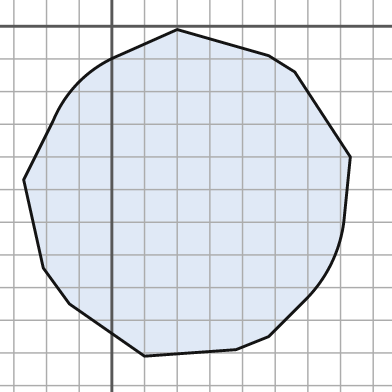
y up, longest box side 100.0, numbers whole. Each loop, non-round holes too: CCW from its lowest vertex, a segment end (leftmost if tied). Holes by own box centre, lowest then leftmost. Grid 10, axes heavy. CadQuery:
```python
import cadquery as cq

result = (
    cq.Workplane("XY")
    .moveTo(10.0, -101.0)
    .lineTo(38.0, -99.0)
    .lineTo(48.0, -95.0)
    .lineTo(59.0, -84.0)
    .threePointArc((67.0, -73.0), (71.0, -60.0))
    .lineTo(73.0, -40.0)
    .lineTo(56.0, -14.0)
    .lineTo(48.0, -9.0)
    .lineTo(20.0, -1.0)
    .lineTo(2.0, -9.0)
    .threePointArc((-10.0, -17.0), (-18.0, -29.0))
    .lineTo(-27.0, -47.0)
    .lineTo(-21.0, -74.0)
    .lineTo(-13.0, -85.0)
    .close()
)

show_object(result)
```